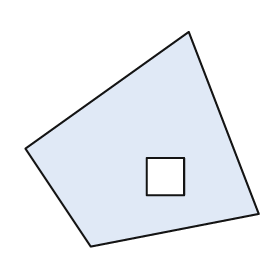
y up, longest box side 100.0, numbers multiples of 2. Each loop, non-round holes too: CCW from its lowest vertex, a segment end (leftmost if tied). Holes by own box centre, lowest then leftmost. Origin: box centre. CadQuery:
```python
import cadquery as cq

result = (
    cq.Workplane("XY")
    .moveTo(-22.0, -46.0)
    .lineTo(50.0, -32.0)
    .lineTo(20.0, 46.0)
    .lineTo(-50.0, -4.0)
    .close()
    .moveTo(2.0, -24.0)
    .lineTo(18.0, -24.0)
    .lineTo(18.0, -8.0)
    .lineTo(2.0, -8.0)
    .close()
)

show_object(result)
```